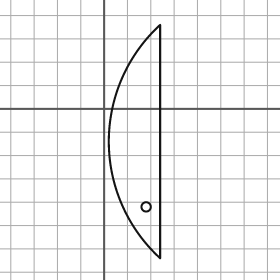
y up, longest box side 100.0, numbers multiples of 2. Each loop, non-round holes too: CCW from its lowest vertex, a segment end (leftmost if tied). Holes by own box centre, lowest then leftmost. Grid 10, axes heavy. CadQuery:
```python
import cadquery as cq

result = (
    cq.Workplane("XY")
    .moveTo(24.0, -64.0)
    .lineTo(24.0, 36.0)
    .threePointArc((2.0, -14.0), (24.0, -64.0))
    .close()
    .moveTo(18.0, -42.0)
    .circle(2.0)
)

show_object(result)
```